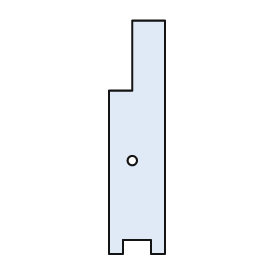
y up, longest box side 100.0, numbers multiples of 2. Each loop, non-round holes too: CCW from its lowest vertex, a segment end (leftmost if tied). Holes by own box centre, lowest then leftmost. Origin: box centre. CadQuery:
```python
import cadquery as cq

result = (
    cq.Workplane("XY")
    .moveTo(-12.0, -50.0)
    .lineTo(-6.0, -50.0)
    .lineTo(-6.0, -44.0)
    .lineTo(6.0, -44.0)
    .lineTo(6.0, -50.0)
    .lineTo(12.0, -50.0)
    .lineTo(12.0, 50.0)
    .lineTo(-2.0, 50.0)
    .lineTo(-2.0, 20.0)
    .lineTo(-12.0, 20.0)
    .close()
    .moveTo(-2.0, -10.0)
    .circle(2.0)
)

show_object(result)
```